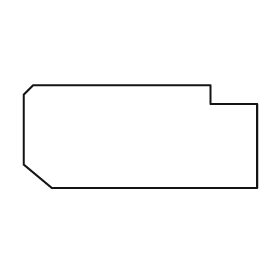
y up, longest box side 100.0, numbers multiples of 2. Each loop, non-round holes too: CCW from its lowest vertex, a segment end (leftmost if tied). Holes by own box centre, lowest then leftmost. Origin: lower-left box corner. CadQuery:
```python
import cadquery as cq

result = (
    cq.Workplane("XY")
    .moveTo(12.0, 0.0)
    .lineTo(100.0, 0.0)
    .lineTo(100.0, 36.0)
    .lineTo(80.0, 36.0)
    .lineTo(80.0, 44.0)
    .lineTo(4.0, 44.0)
    .lineTo(0.0, 40.0)
    .lineTo(0.0, 10.0)
    .close()
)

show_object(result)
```